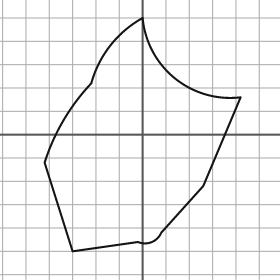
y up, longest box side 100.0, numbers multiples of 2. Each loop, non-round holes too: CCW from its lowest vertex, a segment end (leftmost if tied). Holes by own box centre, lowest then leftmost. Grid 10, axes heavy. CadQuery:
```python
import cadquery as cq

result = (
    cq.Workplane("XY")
    .moveTo(-30.0, -50.0)
    .lineTo(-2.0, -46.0)
    .threePointArc((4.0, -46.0), (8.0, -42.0))
    .lineTo(26.0, -22.0)
    .lineTo(42.0, 16.0)
    .threePointArc((14.0, 24.0), (0.0, 50.0))
    .threePointArc((-14.0, 38.0), (-22.0, 22.0))
    .threePointArc((-34.0, 6.0), (-42.0, -12.0))
    .close()
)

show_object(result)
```